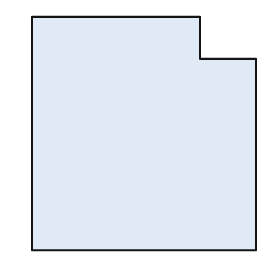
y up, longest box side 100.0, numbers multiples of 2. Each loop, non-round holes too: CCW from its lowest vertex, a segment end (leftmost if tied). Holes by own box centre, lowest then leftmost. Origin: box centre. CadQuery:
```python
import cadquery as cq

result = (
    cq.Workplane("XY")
    .moveTo(-48.0, -50.0)
    .lineTo(48.0, -50.0)
    .lineTo(48.0, 32.0)
    .lineTo(24.0, 32.0)
    .lineTo(24.0, 50.0)
    .lineTo(-48.0, 50.0)
    .close()
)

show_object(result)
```